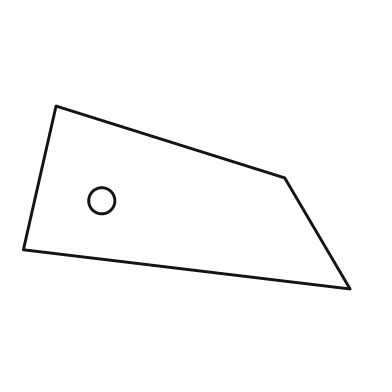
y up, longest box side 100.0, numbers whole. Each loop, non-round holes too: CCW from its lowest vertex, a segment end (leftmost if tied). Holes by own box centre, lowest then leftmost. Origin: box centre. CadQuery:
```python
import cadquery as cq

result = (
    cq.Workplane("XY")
    .moveTo(50.0, -28.0)
    .lineTo(30.0, 6.0)
    .lineTo(-40.0, 28.0)
    .lineTo(-50.0, -16.0)
    .close()
    .moveTo(-26.0, -1.0)
    .circle(4.0)
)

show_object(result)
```